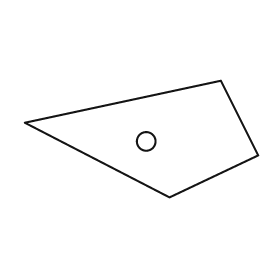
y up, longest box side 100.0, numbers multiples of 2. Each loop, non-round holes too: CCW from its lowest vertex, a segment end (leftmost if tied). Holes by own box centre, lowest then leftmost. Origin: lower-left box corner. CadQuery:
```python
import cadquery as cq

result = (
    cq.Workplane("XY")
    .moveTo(62.0, 0.0)
    .lineTo(100.0, 18.0)
    .lineTo(84.0, 50.0)
    .lineTo(0.0, 32.0)
    .close()
    .moveTo(52.0, 24.0)
    .circle(4.0)
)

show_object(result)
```